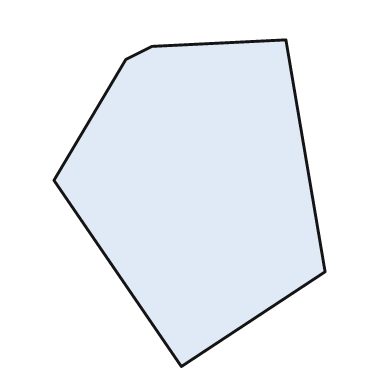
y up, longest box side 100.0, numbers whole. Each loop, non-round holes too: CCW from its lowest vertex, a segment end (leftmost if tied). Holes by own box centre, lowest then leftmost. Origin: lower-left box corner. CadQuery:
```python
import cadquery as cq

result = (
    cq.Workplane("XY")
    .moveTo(39.0, 0.0)
    .lineTo(83.0, 29.0)
    .lineTo(71.0, 100.0)
    .lineTo(30.0, 98.0)
    .lineTo(22.0, 94.0)
    .lineTo(0.0, 57.0)
    .close()
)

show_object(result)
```